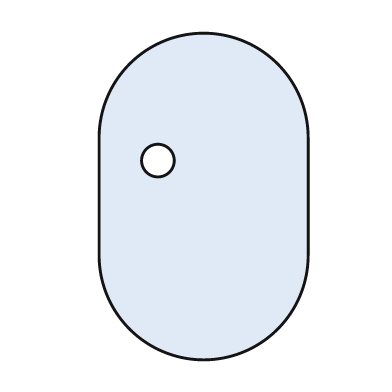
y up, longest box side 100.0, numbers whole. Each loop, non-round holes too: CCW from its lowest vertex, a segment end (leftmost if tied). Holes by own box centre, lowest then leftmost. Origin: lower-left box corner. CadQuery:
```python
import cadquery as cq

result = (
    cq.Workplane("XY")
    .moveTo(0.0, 32.0)
    .threePointArc((32.0, 0.0), (64.0, 32.0))
    .lineTo(64.0, 68.0)
    .threePointArc((32.0, 100.0), (0.0, 68.0))
    .close()
    .moveTo(18.0, 61.0)
    .circle(5.0)
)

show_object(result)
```